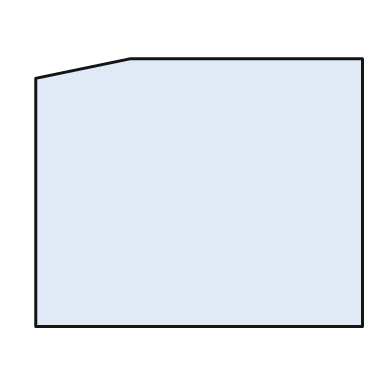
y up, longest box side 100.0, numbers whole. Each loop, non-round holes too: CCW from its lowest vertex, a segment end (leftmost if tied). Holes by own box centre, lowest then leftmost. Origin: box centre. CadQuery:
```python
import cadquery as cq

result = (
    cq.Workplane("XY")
    .moveTo(-50.0, -41.0)
    .lineTo(50.0, -41.0)
    .lineTo(50.0, 41.0)
    .lineTo(-21.0, 41.0)
    .lineTo(-50.0, 35.0)
    .close()
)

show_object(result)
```